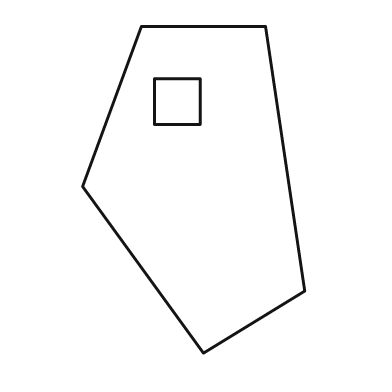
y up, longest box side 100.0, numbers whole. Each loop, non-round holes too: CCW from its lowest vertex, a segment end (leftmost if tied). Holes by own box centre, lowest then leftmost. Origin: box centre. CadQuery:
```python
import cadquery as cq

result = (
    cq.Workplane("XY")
    .moveTo(3.0, -50.0)
    .lineTo(34.0, -31.0)
    .lineTo(22.0, 50.0)
    .lineTo(-16.0, 50.0)
    .lineTo(-34.0, 1.0)
    .close()
    .moveTo(-12.0, 20.0)
    .lineTo(2.0, 20.0)
    .lineTo(2.0, 34.0)
    .lineTo(-12.0, 34.0)
    .close()
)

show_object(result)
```